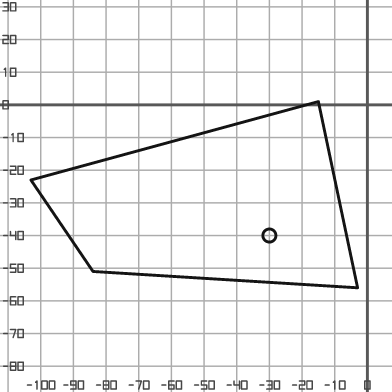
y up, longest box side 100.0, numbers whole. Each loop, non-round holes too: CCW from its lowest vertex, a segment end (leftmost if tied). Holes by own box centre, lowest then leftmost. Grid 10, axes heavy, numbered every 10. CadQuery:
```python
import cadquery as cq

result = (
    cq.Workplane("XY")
    .moveTo(-3.0, -56.0)
    .lineTo(-15.0, 1.0)
    .lineTo(-103.0, -23.0)
    .lineTo(-84.0, -51.0)
    .close()
    .moveTo(-30.0, -40.0)
    .circle(2.0)
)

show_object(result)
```